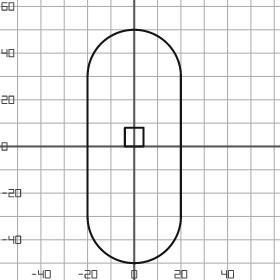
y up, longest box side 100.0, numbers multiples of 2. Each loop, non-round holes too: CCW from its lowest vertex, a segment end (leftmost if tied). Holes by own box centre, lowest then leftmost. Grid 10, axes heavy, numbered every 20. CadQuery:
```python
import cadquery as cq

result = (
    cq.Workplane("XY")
    .moveTo(-20.0, -30.0)
    .threePointArc((0.0, -50.0), (20.0, -30.0))
    .lineTo(20.0, 30.0)
    .threePointArc((0.0, 50.0), (-20.0, 30.0))
    .close()
    .moveTo(-4.0, 0.0)
    .lineTo(4.0, 0.0)
    .lineTo(4.0, 8.0)
    .lineTo(-4.0, 8.0)
    .close()
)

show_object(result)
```